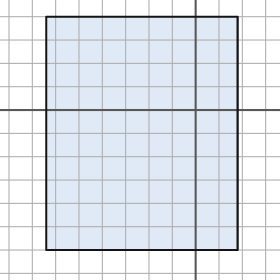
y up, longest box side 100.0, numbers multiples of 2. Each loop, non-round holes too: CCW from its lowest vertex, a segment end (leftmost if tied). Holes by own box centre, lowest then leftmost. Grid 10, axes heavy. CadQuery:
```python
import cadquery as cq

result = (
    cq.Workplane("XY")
    .moveTo(-64.0, -60.0)
    .lineTo(18.0, -60.0)
    .lineTo(18.0, 40.0)
    .lineTo(-64.0, 40.0)
    .close()
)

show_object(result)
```